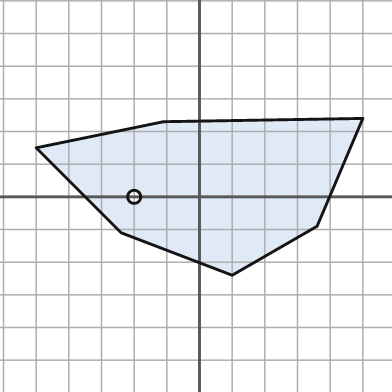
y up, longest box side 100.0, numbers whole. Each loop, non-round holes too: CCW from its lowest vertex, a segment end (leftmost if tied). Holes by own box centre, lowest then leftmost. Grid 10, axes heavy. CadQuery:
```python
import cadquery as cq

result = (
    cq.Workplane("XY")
    .moveTo(10.0, -24.0)
    .lineTo(36.0, -9.0)
    .lineTo(50.0, 24.0)
    .lineTo(-11.0, 23.0)
    .lineTo(-50.0, 15.0)
    .lineTo(-24.0, -11.0)
    .close()
    .moveTo(-20.0, 0.0)
    .circle(2.0)
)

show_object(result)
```